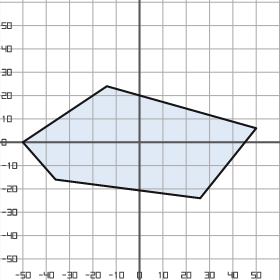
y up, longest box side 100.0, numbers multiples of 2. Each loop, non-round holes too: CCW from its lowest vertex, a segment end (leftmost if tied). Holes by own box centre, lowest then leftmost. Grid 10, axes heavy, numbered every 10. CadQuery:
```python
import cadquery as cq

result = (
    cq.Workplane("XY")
    .moveTo(26.0, -24.0)
    .lineTo(50.0, 6.0)
    .lineTo(-14.0, 24.0)
    .lineTo(-50.0, 0.0)
    .lineTo(-36.0, -16.0)
    .close()
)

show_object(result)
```